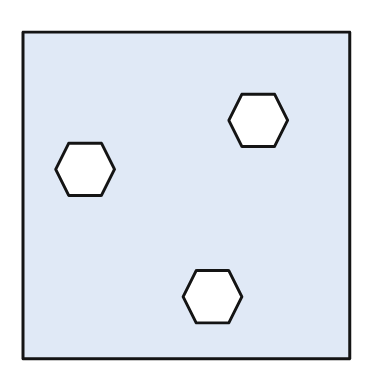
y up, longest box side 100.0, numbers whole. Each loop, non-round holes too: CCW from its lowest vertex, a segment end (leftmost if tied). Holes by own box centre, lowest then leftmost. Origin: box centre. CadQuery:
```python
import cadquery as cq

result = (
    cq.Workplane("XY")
    .moveTo(-50.0, -50.0)
    .lineTo(50.0, -50.0)
    .lineTo(50.0, 50.0)
    .lineTo(-50.0, 50.0)
    .close()
    .moveTo(3.0, -39.0)
    .lineTo(13.0, -39.0)
    .lineTo(17.0, -31.0)
    .lineTo(13.0, -23.0)
    .lineTo(3.0, -23.0)
    .lineTo(-1.0, -31.0)
    .close()
    .moveTo(-36.0, 0.0)
    .lineTo(-26.0, 0.0)
    .lineTo(-22.0, 8.0)
    .lineTo(-26.0, 16.0)
    .lineTo(-36.0, 16.0)
    .lineTo(-40.0, 8.0)
    .close()
    .moveTo(17.0, 15.0)
    .lineTo(27.0, 15.0)
    .lineTo(31.0, 23.0)
    .lineTo(27.0, 31.0)
    .lineTo(17.0, 31.0)
    .lineTo(13.0, 23.0)
    .close()
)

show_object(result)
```